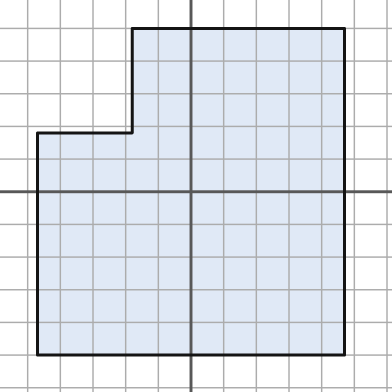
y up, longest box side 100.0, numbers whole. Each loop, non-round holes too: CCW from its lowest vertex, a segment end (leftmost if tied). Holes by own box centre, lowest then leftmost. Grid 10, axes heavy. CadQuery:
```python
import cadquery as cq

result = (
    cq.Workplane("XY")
    .moveTo(-47.0, -50.0)
    .lineTo(47.0, -50.0)
    .lineTo(47.0, 50.0)
    .lineTo(-18.0, 50.0)
    .lineTo(-18.0, 18.0)
    .lineTo(-47.0, 18.0)
    .close()
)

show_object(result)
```